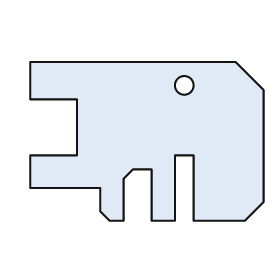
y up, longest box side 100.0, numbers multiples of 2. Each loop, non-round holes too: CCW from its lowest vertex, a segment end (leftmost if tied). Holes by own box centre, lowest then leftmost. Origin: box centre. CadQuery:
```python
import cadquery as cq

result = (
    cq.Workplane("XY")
    .moveTo(-16.0, -34.0)
    .lineTo(-10.0, -34.0)
    .lineTo(-10.0, -16.0)
    .lineTo(-6.0, -12.0)
    .lineTo(2.0, -12.0)
    .lineTo(2.0, -34.0)
    .lineTo(12.0, -34.0)
    .lineTo(12.0, -6.0)
    .lineTo(20.0, -6.0)
    .lineTo(20.0, -34.0)
    .lineTo(42.0, -34.0)
    .lineTo(50.0, -26.0)
    .lineTo(50.0, 22.0)
    .lineTo(38.0, 34.0)
    .lineTo(-50.0, 34.0)
    .lineTo(-50.0, 18.0)
    .lineTo(-30.0, 18.0)
    .lineTo(-30.0, -6.0)
    .lineTo(-50.0, -6.0)
    .lineTo(-50.0, -20.0)
    .lineTo(-20.0, -20.0)
    .lineTo(-20.0, -30.0)
    .close()
    .moveTo(16.0, 24.0)
    .circle(4.0)
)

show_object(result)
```